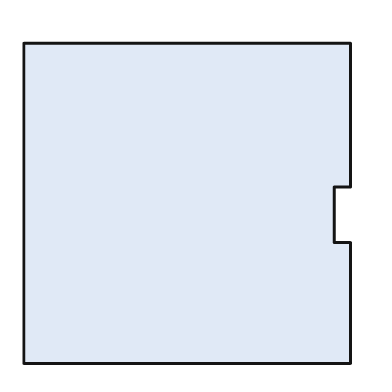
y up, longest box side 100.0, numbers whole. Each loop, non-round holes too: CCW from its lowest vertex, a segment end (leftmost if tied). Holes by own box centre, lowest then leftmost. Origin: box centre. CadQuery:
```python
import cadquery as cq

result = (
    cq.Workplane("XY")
    .moveTo(-50.0, -49.0)
    .lineTo(50.0, -49.0)
    .lineTo(50.0, -12.0)
    .lineTo(45.0, -12.0)
    .lineTo(45.0, 5.0)
    .lineTo(50.0, 5.0)
    .lineTo(50.0, 49.0)
    .lineTo(-50.0, 49.0)
    .close()
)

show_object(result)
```